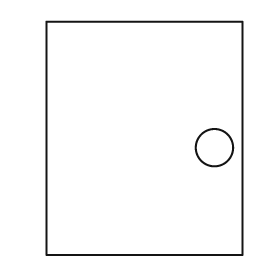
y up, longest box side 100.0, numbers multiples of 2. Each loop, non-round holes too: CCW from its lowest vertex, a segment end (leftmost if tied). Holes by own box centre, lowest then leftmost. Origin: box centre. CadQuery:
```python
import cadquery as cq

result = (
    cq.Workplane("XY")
    .moveTo(-42.0, -50.0)
    .lineTo(42.0, -50.0)
    .lineTo(42.0, 50.0)
    .lineTo(-42.0, 50.0)
    .close()
    .moveTo(30.0, -4.0)
    .circle(8.0)
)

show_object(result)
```